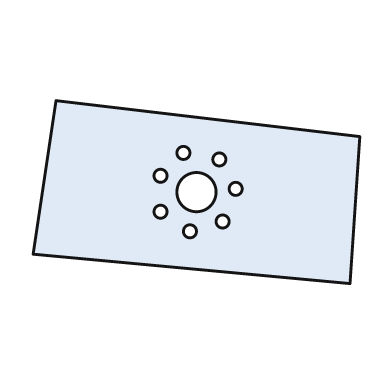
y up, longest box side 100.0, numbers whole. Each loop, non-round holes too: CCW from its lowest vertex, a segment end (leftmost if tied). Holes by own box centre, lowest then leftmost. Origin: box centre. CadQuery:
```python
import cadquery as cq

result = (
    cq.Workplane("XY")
    .moveTo(47.0, -28.0)
    .lineTo(50.0, 17.0)
    .lineTo(-43.0, 28.0)
    .lineTo(-50.0, -19.0)
    .close()
    .moveTo(-2.0, -12.0)
    .circle(2.0)
    .moveTo(8.0, -9.0)
    .circle(2.0)
    .moveTo(-11.0, -6.0)
    .circle(2.0)
    .moveTo(0.0, 0.0)
    .circle(6.0)
    .moveTo(12.0, 1.0)
    .circle(2.0)
    .moveTo(-11.0, 5.0)
    .circle(2.0)
    .moveTo(7.0, 10.0)
    .circle(2.0)
    .moveTo(-4.0, 12.0)
    .circle(2.0)
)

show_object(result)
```